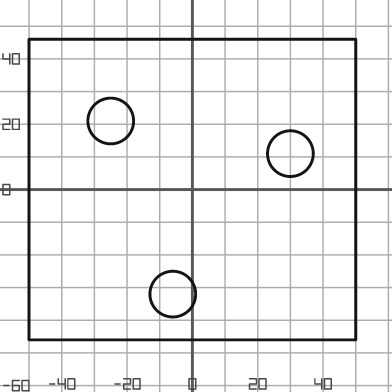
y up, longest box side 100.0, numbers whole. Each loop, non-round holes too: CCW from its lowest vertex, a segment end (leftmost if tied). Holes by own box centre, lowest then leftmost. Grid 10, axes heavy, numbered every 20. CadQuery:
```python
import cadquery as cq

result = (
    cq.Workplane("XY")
    .moveTo(-50.0, -46.0)
    .lineTo(50.0, -46.0)
    .lineTo(50.0, 46.0)
    .lineTo(-50.0, 46.0)
    .close()
    .moveTo(-6.0, -32.0)
    .circle(7.0)
    .moveTo(30.0, 11.0)
    .circle(7.0)
    .moveTo(-25.0, 21.0)
    .circle(7.0)
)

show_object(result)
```